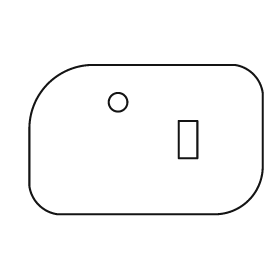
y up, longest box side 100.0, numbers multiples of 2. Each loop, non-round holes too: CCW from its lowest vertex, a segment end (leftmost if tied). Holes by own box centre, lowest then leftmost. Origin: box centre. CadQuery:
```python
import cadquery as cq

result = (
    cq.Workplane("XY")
    .moveTo(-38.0, -32.0)
    .lineTo(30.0, -32.0)
    .threePointArc((44.0, -26.0), (50.0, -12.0))
    .lineTo(50.0, 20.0)
    .threePointArc((46.0, 28.0), (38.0, 32.0))
    .lineTo(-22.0, 32.0)
    .threePointArc((-42.0, 24.0), (-50.0, 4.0))
    .lineTo(-50.0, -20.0)
    .threePointArc((-46.0, -28.0), (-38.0, -32.0))
    .close()
    .moveTo(14.0, -8.0)
    .lineTo(22.0, -8.0)
    .lineTo(22.0, 8.0)
    .lineTo(14.0, 8.0)
    .close()
    .moveTo(-12.0, 16.0)
    .circle(4.0)
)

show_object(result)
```